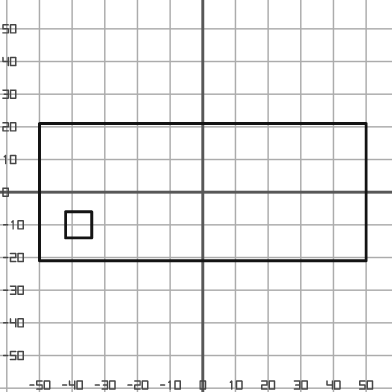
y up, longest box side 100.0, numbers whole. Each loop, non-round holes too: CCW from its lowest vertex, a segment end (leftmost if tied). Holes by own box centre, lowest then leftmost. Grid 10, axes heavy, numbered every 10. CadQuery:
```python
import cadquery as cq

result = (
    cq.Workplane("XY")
    .moveTo(-50.0, -21.0)
    .lineTo(50.0, -21.0)
    .lineTo(50.0, 21.0)
    .lineTo(-50.0, 21.0)
    .close()
    .moveTo(-42.0, -14.0)
    .lineTo(-34.0, -14.0)
    .lineTo(-34.0, -6.0)
    .lineTo(-42.0, -6.0)
    .close()
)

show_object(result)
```